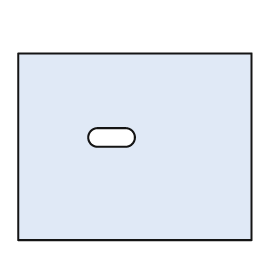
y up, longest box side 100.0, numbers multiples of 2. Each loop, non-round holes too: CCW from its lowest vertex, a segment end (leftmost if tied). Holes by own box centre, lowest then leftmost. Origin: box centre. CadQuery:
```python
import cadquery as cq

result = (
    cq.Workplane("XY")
    .moveTo(-50.0, -40.0)
    .lineTo(50.0, -40.0)
    .lineTo(50.0, 40.0)
    .lineTo(-50.0, 40.0)
    .close()
    .moveTo(-16.0, 0.0)
    .lineTo(-4.0, 0.0)
    .threePointArc((0.0, 4.0), (-4.0, 8.0))
    .lineTo(-16.0, 8.0)
    .threePointArc((-20.0, 4.0), (-16.0, 0.0))
    .close()
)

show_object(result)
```